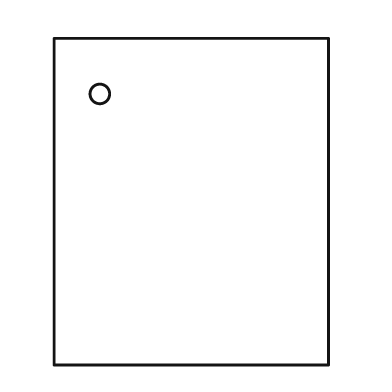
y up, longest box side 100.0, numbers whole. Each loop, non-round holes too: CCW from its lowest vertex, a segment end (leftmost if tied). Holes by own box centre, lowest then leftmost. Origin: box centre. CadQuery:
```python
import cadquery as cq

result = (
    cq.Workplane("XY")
    .moveTo(-42.0, -50.0)
    .lineTo(42.0, -50.0)
    .lineTo(42.0, 50.0)
    .lineTo(-42.0, 50.0)
    .close()
    .moveTo(-28.0, 33.0)
    .circle(3.0)
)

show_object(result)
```